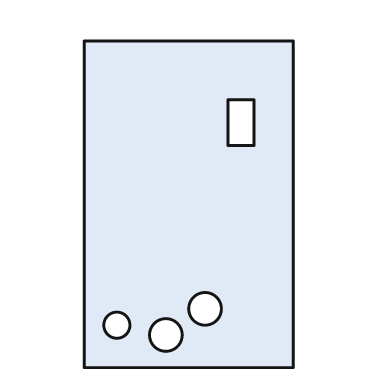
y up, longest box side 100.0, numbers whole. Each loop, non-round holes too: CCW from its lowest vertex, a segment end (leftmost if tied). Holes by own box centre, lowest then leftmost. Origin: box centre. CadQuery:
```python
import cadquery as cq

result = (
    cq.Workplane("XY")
    .moveTo(-32.0, -50.0)
    .lineTo(32.0, -50.0)
    .lineTo(32.0, 50.0)
    .lineTo(-32.0, 50.0)
    .close()
    .moveTo(-7.0, -40.0)
    .circle(5.0)
    .moveTo(-22.0, -37.0)
    .circle(4.0)
    .moveTo(5.0, -32.0)
    .circle(5.0)
    .moveTo(12.0, 18.0)
    .lineTo(20.0, 18.0)
    .lineTo(20.0, 32.0)
    .lineTo(12.0, 32.0)
    .close()
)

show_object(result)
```